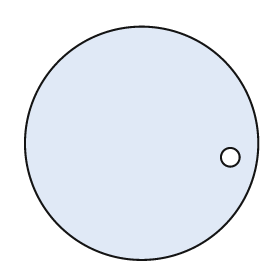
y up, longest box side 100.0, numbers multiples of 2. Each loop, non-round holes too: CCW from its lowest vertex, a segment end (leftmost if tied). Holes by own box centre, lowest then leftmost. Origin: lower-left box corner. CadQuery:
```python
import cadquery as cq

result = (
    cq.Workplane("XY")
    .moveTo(50.0, 50.0)
    .circle(50.0)
    .moveTo(88.0, 44.0)
    .circle(4.0)
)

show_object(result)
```